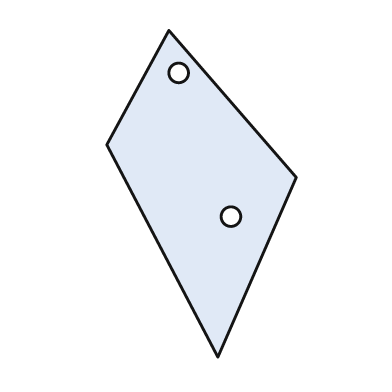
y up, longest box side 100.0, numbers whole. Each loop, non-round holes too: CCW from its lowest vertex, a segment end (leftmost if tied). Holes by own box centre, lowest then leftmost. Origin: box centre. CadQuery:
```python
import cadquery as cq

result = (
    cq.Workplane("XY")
    .moveTo(5.0, -50.0)
    .lineTo(29.0, 5.0)
    .lineTo(-10.0, 50.0)
    .lineTo(-29.0, 15.0)
    .close()
    .moveTo(9.0, -7.0)
    .circle(3.0)
    .moveTo(-7.0, 37.0)
    .circle(3.0)
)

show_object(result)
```